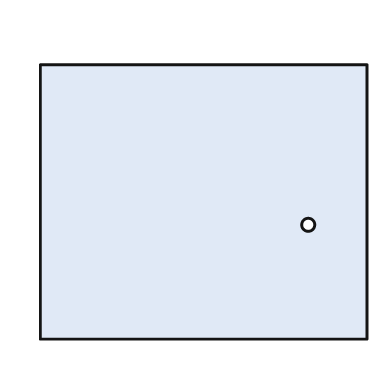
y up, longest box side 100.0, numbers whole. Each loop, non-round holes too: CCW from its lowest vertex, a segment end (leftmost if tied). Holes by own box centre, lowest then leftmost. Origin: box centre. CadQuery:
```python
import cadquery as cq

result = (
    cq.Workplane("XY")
    .moveTo(-50.0, -42.0)
    .lineTo(50.0, -42.0)
    .lineTo(50.0, 42.0)
    .lineTo(-50.0, 42.0)
    .close()
    .moveTo(32.0, -7.0)
    .circle(2.0)
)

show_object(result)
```